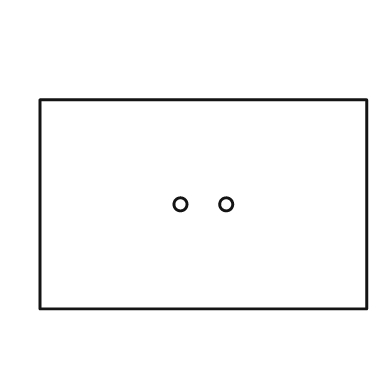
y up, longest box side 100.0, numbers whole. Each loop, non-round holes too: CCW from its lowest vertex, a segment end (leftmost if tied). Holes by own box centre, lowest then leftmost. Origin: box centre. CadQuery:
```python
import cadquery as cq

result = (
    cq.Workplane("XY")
    .moveTo(-50.0, -32.0)
    .lineTo(50.0, -32.0)
    .lineTo(50.0, 32.0)
    .lineTo(-50.0, 32.0)
    .close()
    .moveTo(-7.0, 0.0)
    .circle(2.0)
    .moveTo(7.0, 0.0)
    .circle(2.0)
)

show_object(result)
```